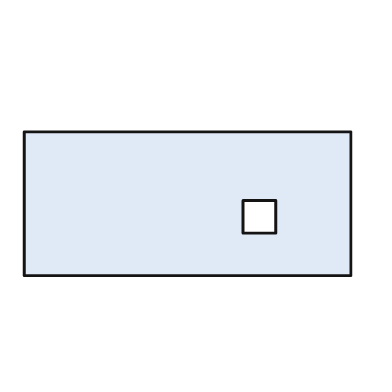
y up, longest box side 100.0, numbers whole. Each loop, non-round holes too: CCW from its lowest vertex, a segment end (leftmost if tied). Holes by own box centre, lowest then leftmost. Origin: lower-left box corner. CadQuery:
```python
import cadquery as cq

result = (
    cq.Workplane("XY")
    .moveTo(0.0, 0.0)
    .lineTo(100.0, 0.0)
    .lineTo(100.0, 44.0)
    .lineTo(0.0, 44.0)
    .close()
    .moveTo(67.0, 13.0)
    .lineTo(77.0, 13.0)
    .lineTo(77.0, 23.0)
    .lineTo(67.0, 23.0)
    .close()
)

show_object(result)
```